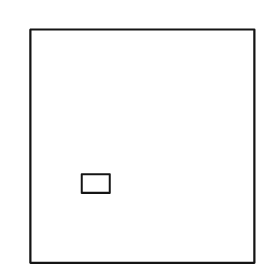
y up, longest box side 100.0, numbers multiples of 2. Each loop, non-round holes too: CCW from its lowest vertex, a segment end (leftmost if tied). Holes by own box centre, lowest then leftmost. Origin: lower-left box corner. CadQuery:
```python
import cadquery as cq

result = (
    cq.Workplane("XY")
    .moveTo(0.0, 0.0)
    .lineTo(96.0, 0.0)
    .lineTo(96.0, 100.0)
    .lineTo(0.0, 100.0)
    .close()
    .moveTo(22.0, 30.0)
    .lineTo(34.0, 30.0)
    .lineTo(34.0, 38.0)
    .lineTo(22.0, 38.0)
    .close()
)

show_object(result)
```